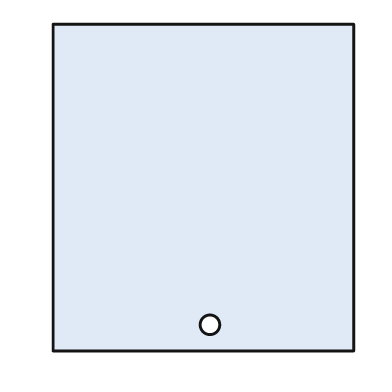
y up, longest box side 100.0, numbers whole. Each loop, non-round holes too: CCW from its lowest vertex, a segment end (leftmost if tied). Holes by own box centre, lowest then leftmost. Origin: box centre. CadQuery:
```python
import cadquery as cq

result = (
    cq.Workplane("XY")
    .moveTo(-46.0, -50.0)
    .lineTo(46.0, -50.0)
    .lineTo(46.0, 50.0)
    .lineTo(-46.0, 50.0)
    .close()
    .moveTo(2.0, -42.0)
    .circle(3.0)
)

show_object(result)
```